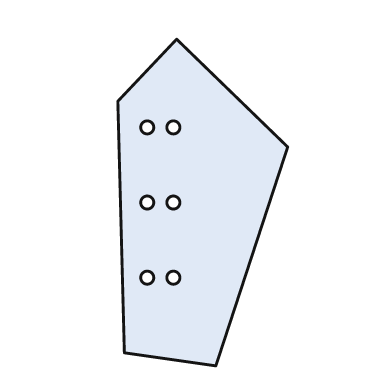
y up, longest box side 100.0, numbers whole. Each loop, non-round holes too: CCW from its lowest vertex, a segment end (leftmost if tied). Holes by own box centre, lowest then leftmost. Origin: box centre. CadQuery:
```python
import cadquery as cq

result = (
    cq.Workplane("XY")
    .moveTo(4.0, -50.0)
    .lineTo(26.0, 17.0)
    .lineTo(-8.0, 50.0)
    .lineTo(-26.0, 31.0)
    .lineTo(-24.0, -46.0)
    .close()
    .moveTo(-17.0, -23.0)
    .circle(2.0)
    .moveTo(-9.0, -23.0)
    .circle(2.0)
    .moveTo(-17.0, 0.0)
    .circle(2.0)
    .moveTo(-9.0, 0.0)
    .circle(2.0)
    .moveTo(-17.0, 23.0)
    .circle(2.0)
    .moveTo(-9.0, 23.0)
    .circle(2.0)
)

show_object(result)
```